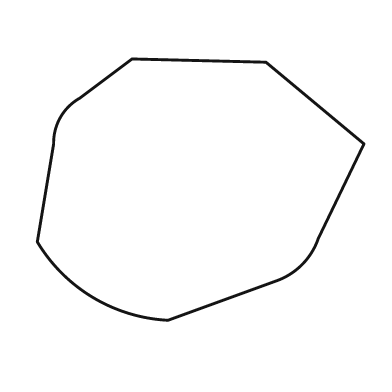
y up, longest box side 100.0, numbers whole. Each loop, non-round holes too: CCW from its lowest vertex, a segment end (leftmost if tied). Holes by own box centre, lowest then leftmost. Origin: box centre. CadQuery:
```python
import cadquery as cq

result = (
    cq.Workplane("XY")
    .moveTo(-10.0, -40.0)
    .lineTo(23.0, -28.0)
    .threePointArc((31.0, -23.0), (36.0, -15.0))
    .lineTo(50.0, 14.0)
    .lineTo(20.0, 39.0)
    .lineTo(-21.0, 40.0)
    .lineTo(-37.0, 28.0)
    .threePointArc((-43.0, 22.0), (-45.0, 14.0))
    .lineTo(-50.0, -16.0)
    .threePointArc((-33.0, -33.0), (-10.0, -40.0))
    .close()
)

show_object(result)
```